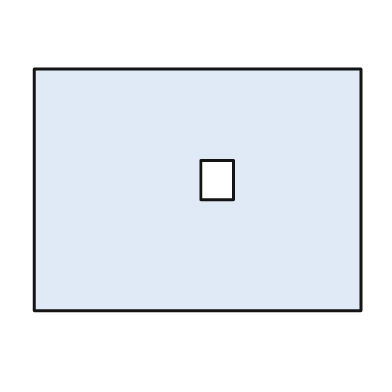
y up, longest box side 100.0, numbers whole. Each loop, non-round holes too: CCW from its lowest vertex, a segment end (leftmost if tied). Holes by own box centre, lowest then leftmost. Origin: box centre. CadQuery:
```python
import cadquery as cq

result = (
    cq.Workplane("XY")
    .moveTo(-50.0, -37.0)
    .lineTo(50.0, -37.0)
    .lineTo(50.0, 37.0)
    .lineTo(-50.0, 37.0)
    .close()
    .moveTo(1.0, -3.0)
    .lineTo(11.0, -3.0)
    .lineTo(11.0, 9.0)
    .lineTo(1.0, 9.0)
    .close()
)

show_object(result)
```